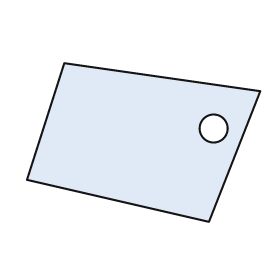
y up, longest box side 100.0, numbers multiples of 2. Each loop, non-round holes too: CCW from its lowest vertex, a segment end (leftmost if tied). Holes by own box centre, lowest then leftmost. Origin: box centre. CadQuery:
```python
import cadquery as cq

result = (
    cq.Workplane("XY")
    .moveTo(28.0, -34.0)
    .lineTo(50.0, 22.0)
    .lineTo(-34.0, 34.0)
    .lineTo(-50.0, -16.0)
    .close()
    .moveTo(30.0, 6.0)
    .circle(6.0)
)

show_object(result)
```